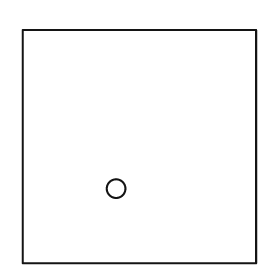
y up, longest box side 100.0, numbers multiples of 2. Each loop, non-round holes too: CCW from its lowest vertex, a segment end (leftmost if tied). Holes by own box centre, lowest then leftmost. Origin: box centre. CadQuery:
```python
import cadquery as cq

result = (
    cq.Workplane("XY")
    .moveTo(-50.0, -50.0)
    .lineTo(50.0, -50.0)
    .lineTo(50.0, 50.0)
    .lineTo(-50.0, 50.0)
    .close()
    .moveTo(-10.0, -18.0)
    .circle(4.0)
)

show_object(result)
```